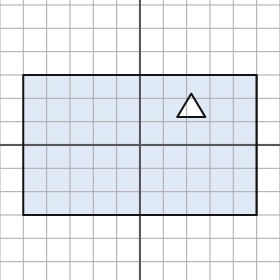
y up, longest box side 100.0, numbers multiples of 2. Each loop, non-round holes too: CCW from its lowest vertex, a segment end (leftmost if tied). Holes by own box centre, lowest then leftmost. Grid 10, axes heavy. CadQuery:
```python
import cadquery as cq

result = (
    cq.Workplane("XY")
    .moveTo(-50.0, -30.0)
    .lineTo(50.0, -30.0)
    .lineTo(50.0, 30.0)
    .lineTo(-50.0, 30.0)
    .close()
    .moveTo(16.0, 12.0)
    .lineTo(28.0, 12.0)
    .lineTo(22.0, 22.0)
    .close()
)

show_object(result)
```